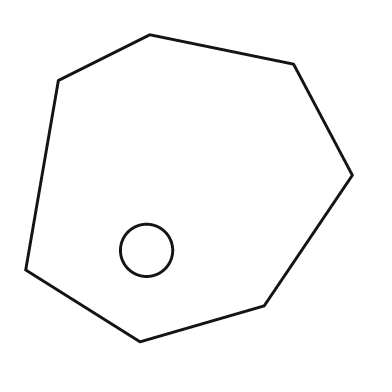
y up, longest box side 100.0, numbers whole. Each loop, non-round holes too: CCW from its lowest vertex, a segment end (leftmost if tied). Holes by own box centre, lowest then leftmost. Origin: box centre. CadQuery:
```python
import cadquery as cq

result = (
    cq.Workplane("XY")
    .moveTo(-15.0, -47.0)
    .lineTo(23.0, -36.0)
    .lineTo(50.0, 4.0)
    .lineTo(32.0, 38.0)
    .lineTo(-12.0, 47.0)
    .lineTo(-40.0, 33.0)
    .lineTo(-50.0, -25.0)
    .close()
    .moveTo(-13.0, -19.0)
    .circle(8.0)
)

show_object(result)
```